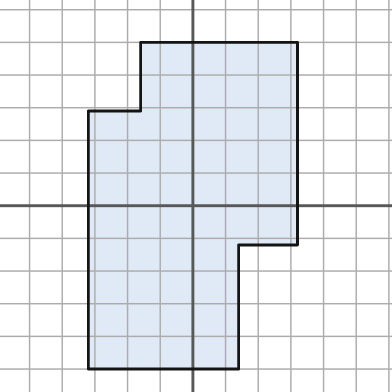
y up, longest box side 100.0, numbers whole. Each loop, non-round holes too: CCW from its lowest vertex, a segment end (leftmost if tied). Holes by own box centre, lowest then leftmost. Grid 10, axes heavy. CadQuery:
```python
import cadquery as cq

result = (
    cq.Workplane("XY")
    .moveTo(-32.0, -50.0)
    .lineTo(14.0, -50.0)
    .lineTo(14.0, -12.0)
    .lineTo(32.0, -12.0)
    .lineTo(32.0, 50.0)
    .lineTo(-16.0, 50.0)
    .lineTo(-16.0, 29.0)
    .lineTo(-32.0, 29.0)
    .close()
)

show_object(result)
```